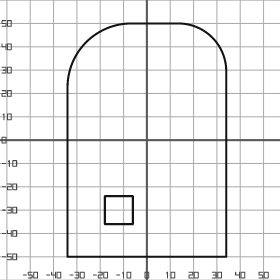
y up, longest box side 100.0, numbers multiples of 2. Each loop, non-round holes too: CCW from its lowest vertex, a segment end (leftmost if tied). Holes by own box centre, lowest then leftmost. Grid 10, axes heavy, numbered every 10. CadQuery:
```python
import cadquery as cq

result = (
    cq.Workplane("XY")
    .moveTo(-34.0, -50.0)
    .lineTo(34.0, -50.0)
    .lineTo(34.0, 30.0)
    .threePointArc((28.0, 44.0), (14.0, 50.0))
    .lineTo(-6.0, 50.0)
    .threePointArc((-26.0, 42.0), (-34.0, 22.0))
    .close()
    .moveTo(-18.0, -36.0)
    .lineTo(-6.0, -36.0)
    .lineTo(-6.0, -24.0)
    .lineTo(-18.0, -24.0)
    .close()
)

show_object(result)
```